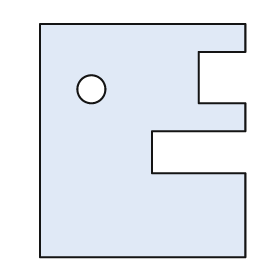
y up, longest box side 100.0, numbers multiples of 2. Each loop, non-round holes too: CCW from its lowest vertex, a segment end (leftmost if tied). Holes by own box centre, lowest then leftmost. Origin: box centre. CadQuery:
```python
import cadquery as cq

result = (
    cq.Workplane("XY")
    .moveTo(-44.0, -50.0)
    .lineTo(44.0, -50.0)
    .lineTo(44.0, -14.0)
    .lineTo(4.0, -14.0)
    .lineTo(4.0, 4.0)
    .lineTo(44.0, 4.0)
    .lineTo(44.0, 16.0)
    .lineTo(24.0, 16.0)
    .lineTo(24.0, 38.0)
    .lineTo(44.0, 38.0)
    .lineTo(44.0, 50.0)
    .lineTo(-44.0, 50.0)
    .close()
    .moveTo(-22.0, 22.0)
    .circle(6.0)
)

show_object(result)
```